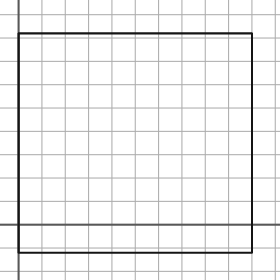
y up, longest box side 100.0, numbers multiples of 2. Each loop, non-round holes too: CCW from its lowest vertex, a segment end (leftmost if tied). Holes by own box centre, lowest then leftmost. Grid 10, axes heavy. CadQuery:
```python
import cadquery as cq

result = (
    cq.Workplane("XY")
    .moveTo(0.0, -12.0)
    .lineTo(100.0, -12.0)
    .lineTo(100.0, 82.0)
    .lineTo(0.0, 82.0)
    .close()
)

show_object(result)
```